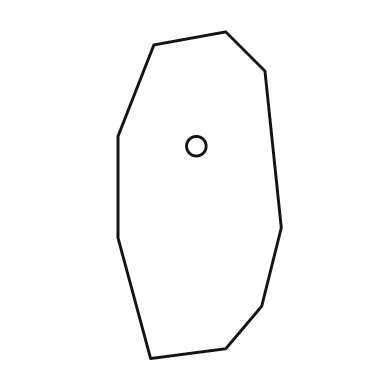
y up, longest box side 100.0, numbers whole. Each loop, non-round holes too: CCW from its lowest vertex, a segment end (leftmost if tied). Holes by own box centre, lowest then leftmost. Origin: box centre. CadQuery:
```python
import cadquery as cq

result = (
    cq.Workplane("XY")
    .moveTo(-15.0, -50.0)
    .lineTo(8.0, -47.0)
    .lineTo(19.0, -34.0)
    .lineTo(25.0, -10.0)
    .lineTo(20.0, 38.0)
    .lineTo(8.0, 50.0)
    .lineTo(-14.0, 46.0)
    .lineTo(-25.0, 18.0)
    .lineTo(-25.0, -13.0)
    .close()
    .moveTo(-1.0, 15.0)
    .circle(3.0)
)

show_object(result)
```